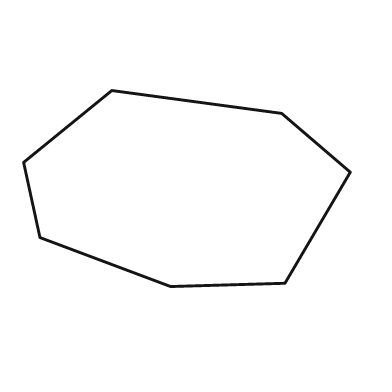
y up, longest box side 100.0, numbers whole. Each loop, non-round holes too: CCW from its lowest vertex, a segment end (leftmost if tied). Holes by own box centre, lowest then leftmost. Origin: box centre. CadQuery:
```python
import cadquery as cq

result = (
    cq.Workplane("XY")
    .moveTo(-5.0, -30.0)
    .lineTo(30.0, -29.0)
    .lineTo(50.0, 5.0)
    .lineTo(29.0, 23.0)
    .lineTo(-23.0, 30.0)
    .lineTo(-50.0, 8.0)
    .lineTo(-45.0, -15.0)
    .close()
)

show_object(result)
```